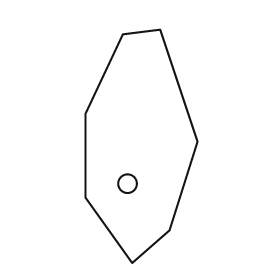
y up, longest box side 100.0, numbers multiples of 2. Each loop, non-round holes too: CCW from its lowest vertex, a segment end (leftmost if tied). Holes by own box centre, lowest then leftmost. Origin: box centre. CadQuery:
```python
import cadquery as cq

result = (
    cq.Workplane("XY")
    .moveTo(-4.0, -50.0)
    .lineTo(12.0, -36.0)
    .lineTo(24.0, 2.0)
    .lineTo(8.0, 50.0)
    .lineTo(-8.0, 48.0)
    .lineTo(-24.0, 14.0)
    .lineTo(-24.0, -22.0)
    .close()
    .moveTo(-6.0, -16.0)
    .circle(4.0)
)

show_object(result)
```